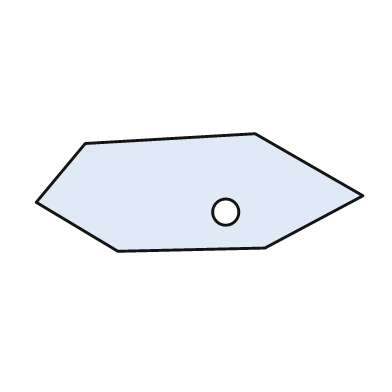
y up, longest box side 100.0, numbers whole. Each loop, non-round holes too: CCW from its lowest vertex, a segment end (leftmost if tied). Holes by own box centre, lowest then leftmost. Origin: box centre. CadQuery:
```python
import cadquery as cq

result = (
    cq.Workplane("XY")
    .moveTo(-25.0, -18.0)
    .lineTo(20.0, -17.0)
    .lineTo(50.0, -1.0)
    .lineTo(17.0, 18.0)
    .lineTo(-35.0, 15.0)
    .lineTo(-50.0, -3.0)
    .close()
    .moveTo(8.0, -6.0)
    .circle(4.0)
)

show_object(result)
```